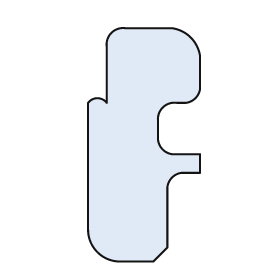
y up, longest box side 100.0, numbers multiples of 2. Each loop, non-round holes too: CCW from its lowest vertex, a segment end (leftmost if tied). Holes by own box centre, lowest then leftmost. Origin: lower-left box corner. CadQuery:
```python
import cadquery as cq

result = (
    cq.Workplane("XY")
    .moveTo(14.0, 0.0)
    .lineTo(28.0, 0.0)
    .lineTo(34.0, 6.0)
    .lineTo(34.0, 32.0)
    .threePointArc((36.0, 36.0), (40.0, 38.0))
    .lineTo(48.0, 38.0)
    .lineTo(48.0, 46.0)
    .lineTo(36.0, 46.0)
    .threePointArc((32.0, 48.0), (30.0, 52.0))
    .lineTo(30.0, 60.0)
    .threePointArc((32.0, 66.0), (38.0, 68.0))
    .lineTo(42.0, 68.0)
    .threePointArc((46.0, 70.0), (48.0, 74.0))
    .lineTo(48.0, 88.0)
    .threePointArc((44.0, 96.0), (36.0, 100.0))
    .lineTo(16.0, 100.0)
    .threePointArc((10.0, 98.0), (8.0, 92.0))
    .lineTo(8.0, 68.0)
    .threePointArc((4.0, 70.0), (0.0, 68.0))
    .lineTo(0.0, 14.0)
    .threePointArc((4.0, 4.0), (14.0, 0.0))
    .close()
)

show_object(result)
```